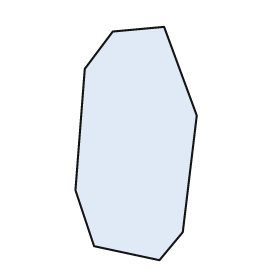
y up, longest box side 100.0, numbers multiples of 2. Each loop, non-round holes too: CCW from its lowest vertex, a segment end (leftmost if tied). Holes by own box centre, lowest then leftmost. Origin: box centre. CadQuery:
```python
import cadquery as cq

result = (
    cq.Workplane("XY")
    .moveTo(10.0, -50.0)
    .lineTo(20.0, -38.0)
    .lineTo(26.0, 12.0)
    .lineTo(12.0, 50.0)
    .lineTo(-10.0, 48.0)
    .lineTo(-22.0, 32.0)
    .lineTo(-26.0, -20.0)
    .lineTo(-18.0, -44.0)
    .close()
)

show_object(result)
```